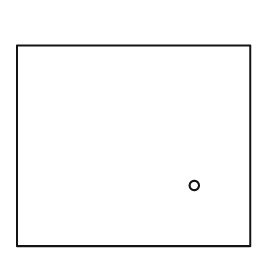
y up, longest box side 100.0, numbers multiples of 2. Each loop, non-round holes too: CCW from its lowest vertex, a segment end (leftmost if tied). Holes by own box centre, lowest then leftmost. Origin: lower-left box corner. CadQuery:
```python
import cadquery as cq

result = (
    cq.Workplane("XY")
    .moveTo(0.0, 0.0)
    .lineTo(100.0, 0.0)
    .lineTo(100.0, 86.0)
    .lineTo(0.0, 86.0)
    .close()
    .moveTo(76.0, 26.0)
    .circle(2.0)
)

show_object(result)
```